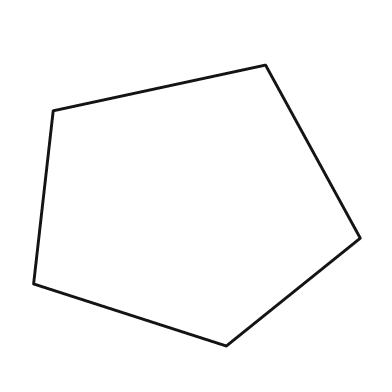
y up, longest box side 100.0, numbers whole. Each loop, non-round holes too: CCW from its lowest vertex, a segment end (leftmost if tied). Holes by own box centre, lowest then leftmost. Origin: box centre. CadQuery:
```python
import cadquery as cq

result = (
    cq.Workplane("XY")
    .moveTo(9.0, -43.0)
    .lineTo(50.0, -10.0)
    .lineTo(21.0, 43.0)
    .lineTo(-44.0, 29.0)
    .lineTo(-50.0, -24.0)
    .close()
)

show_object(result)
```